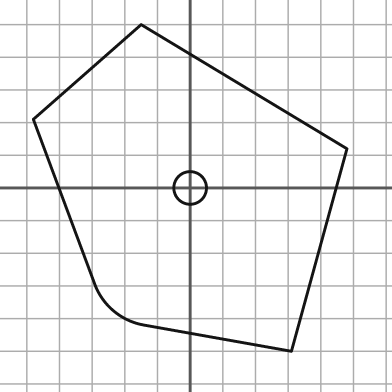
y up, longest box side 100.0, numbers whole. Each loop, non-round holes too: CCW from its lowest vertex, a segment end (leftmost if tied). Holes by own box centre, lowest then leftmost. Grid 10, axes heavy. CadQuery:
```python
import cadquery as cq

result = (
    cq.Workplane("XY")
    .moveTo(31.0, -50.0)
    .lineTo(48.0, 12.0)
    .lineTo(-15.0, 50.0)
    .lineTo(-48.0, 21.0)
    .lineTo(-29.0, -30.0)
    .threePointArc((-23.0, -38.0), (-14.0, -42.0))
    .close()
    .moveTo(0.0, 0.0)
    .circle(5.0)
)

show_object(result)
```